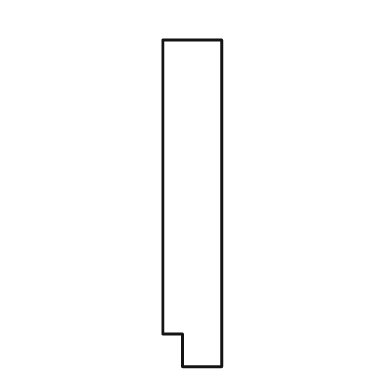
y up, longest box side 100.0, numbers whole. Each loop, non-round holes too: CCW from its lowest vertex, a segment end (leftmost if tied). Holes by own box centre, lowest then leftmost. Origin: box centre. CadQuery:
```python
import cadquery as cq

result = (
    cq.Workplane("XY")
    .moveTo(-3.0, -50.0)
    .lineTo(9.0, -50.0)
    .lineTo(9.0, 50.0)
    .lineTo(-9.0, 50.0)
    .lineTo(-9.0, -40.0)
    .lineTo(-3.0, -40.0)
    .close()
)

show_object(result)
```